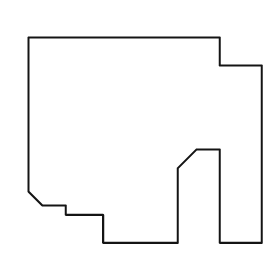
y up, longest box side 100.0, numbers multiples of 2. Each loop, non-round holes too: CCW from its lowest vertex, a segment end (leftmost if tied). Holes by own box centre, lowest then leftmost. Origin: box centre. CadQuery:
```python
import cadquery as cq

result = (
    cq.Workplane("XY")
    .moveTo(-18.0, -44.0)
    .lineTo(14.0, -44.0)
    .lineTo(14.0, -12.0)
    .lineTo(22.0, -4.0)
    .lineTo(32.0, -4.0)
    .lineTo(32.0, -44.0)
    .lineTo(50.0, -44.0)
    .lineTo(50.0, 32.0)
    .lineTo(32.0, 32.0)
    .lineTo(32.0, 44.0)
    .lineTo(-50.0, 44.0)
    .lineTo(-50.0, -22.0)
    .lineTo(-44.0, -28.0)
    .lineTo(-34.0, -28.0)
    .lineTo(-34.0, -32.0)
    .lineTo(-18.0, -32.0)
    .close()
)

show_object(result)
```